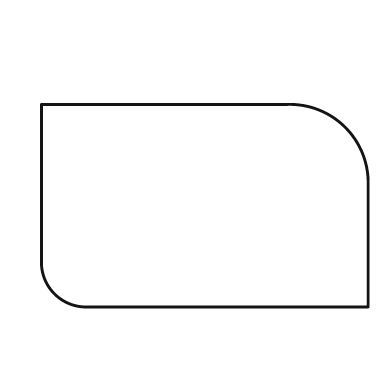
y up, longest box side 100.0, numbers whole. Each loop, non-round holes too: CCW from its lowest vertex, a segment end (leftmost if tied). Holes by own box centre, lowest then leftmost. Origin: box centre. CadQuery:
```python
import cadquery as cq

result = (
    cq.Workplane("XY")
    .moveTo(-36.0, -31.0)
    .lineTo(50.0, -31.0)
    .lineTo(50.0, 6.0)
    .threePointArc((43.0, 24.0), (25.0, 31.0))
    .lineTo(-50.0, 31.0)
    .lineTo(-50.0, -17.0)
    .threePointArc((-46.0, -27.0), (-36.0, -31.0))
    .close()
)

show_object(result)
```